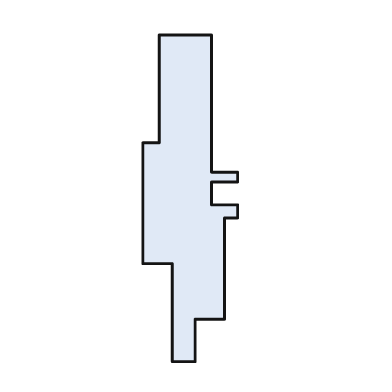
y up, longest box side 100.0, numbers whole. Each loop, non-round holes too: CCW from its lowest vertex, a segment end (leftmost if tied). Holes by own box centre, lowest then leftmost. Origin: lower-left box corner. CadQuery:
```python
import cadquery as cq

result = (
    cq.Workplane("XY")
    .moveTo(9.0, 0.0)
    .lineTo(16.0, 0.0)
    .lineTo(16.0, 13.0)
    .lineTo(25.0, 13.0)
    .lineTo(25.0, 44.0)
    .lineTo(29.0, 44.0)
    .lineTo(29.0, 48.0)
    .lineTo(21.0, 48.0)
    .lineTo(21.0, 55.0)
    .lineTo(29.0, 55.0)
    .lineTo(29.0, 58.0)
    .lineTo(21.0, 58.0)
    .lineTo(21.0, 100.0)
    .lineTo(5.0, 100.0)
    .lineTo(5.0, 67.0)
    .lineTo(0.0, 67.0)
    .lineTo(0.0, 30.0)
    .lineTo(9.0, 30.0)
    .close()
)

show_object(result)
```